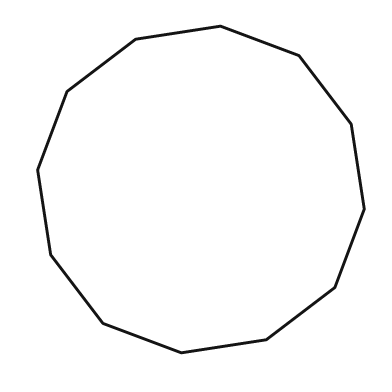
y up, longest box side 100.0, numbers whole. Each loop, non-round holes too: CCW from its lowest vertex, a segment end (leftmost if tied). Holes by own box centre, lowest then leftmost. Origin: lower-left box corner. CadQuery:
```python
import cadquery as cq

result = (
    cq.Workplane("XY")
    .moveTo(44.0, 0.0)
    .lineTo(70.0, 4.0)
    .lineTo(91.0, 20.0)
    .lineTo(100.0, 44.0)
    .lineTo(96.0, 70.0)
    .lineTo(80.0, 91.0)
    .lineTo(56.0, 100.0)
    .lineTo(30.0, 96.0)
    .lineTo(9.0, 80.0)
    .lineTo(0.0, 56.0)
    .lineTo(4.0, 30.0)
    .lineTo(20.0, 9.0)
    .close()
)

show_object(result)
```